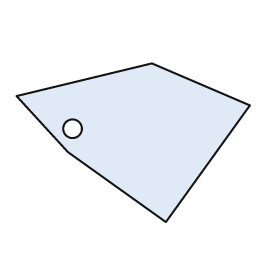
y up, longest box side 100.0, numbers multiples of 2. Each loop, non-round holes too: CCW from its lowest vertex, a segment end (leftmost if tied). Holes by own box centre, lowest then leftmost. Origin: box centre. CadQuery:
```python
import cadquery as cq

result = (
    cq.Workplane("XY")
    .moveTo(14.0, -34.0)
    .lineTo(50.0, 16.0)
    .lineTo(8.0, 34.0)
    .lineTo(-50.0, 20.0)
    .lineTo(-28.0, -4.0)
    .close()
    .moveTo(-26.0, 6.0)
    .circle(4.0)
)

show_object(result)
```